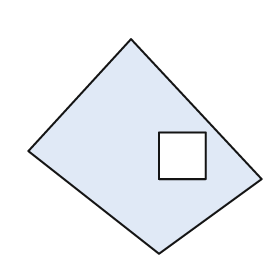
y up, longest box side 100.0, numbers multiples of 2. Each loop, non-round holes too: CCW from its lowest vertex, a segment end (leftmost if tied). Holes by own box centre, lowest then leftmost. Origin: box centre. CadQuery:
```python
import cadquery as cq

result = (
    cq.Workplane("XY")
    .moveTo(6.0, -46.0)
    .lineTo(50.0, -14.0)
    .lineTo(-6.0, 46.0)
    .lineTo(-50.0, -2.0)
    .close()
    .moveTo(6.0, -14.0)
    .lineTo(26.0, -14.0)
    .lineTo(26.0, 6.0)
    .lineTo(6.0, 6.0)
    .close()
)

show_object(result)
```